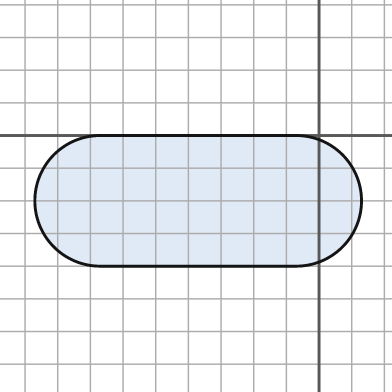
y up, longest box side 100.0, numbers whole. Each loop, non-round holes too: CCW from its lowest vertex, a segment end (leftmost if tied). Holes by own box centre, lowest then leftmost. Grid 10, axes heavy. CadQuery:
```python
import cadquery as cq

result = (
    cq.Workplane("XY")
    .moveTo(-67.0, -40.0)
    .lineTo(-7.0, -40.0)
    .threePointArc((13.0, -20.0), (-7.0, 0.0))
    .lineTo(-67.0, 0.0)
    .threePointArc((-87.0, -20.0), (-67.0, -40.0))
    .close()
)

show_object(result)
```